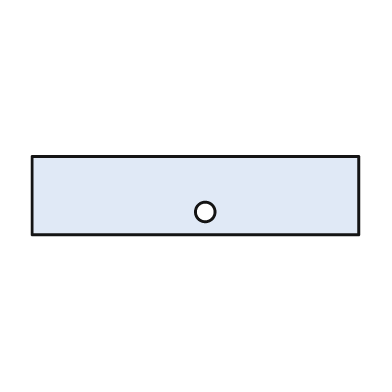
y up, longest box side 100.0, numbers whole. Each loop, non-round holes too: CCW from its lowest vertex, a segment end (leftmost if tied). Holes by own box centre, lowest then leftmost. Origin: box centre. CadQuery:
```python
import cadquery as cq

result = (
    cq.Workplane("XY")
    .moveTo(-50.0, -12.0)
    .lineTo(50.0, -12.0)
    .lineTo(50.0, 12.0)
    .lineTo(-50.0, 12.0)
    .close()
    .moveTo(3.0, -5.0)
    .circle(3.0)
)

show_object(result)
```